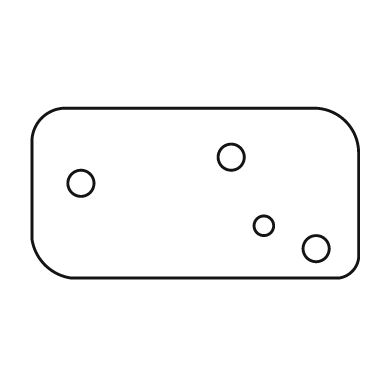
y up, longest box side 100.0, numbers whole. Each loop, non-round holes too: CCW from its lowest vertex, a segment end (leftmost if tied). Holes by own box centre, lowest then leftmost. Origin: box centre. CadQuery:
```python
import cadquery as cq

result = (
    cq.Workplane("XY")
    .moveTo(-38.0, -26.0)
    .lineTo(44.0, -26.0)
    .threePointArc((48.0, -24.0), (50.0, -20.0))
    .lineTo(50.0, 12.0)
    .threePointArc((46.0, 22.0), (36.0, 26.0))
    .lineTo(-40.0, 26.0)
    .threePointArc((-47.0, 23.0), (-50.0, 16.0))
    .lineTo(-50.0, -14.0)
    .threePointArc((-46.0, -22.0), (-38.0, -26.0))
    .close()
    .moveTo(37.0, -17.0)
    .circle(4.0)
    .moveTo(21.0, -10.0)
    .circle(3.0)
    .moveTo(-35.0, 3.0)
    .circle(4.0)
    .moveTo(11.0, 11.0)
    .circle(4.0)
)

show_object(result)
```